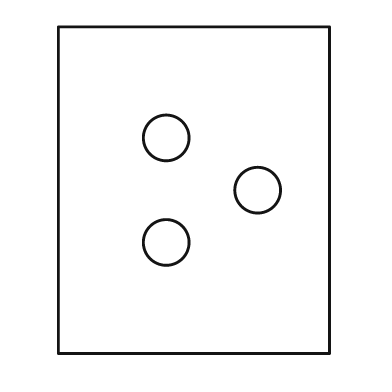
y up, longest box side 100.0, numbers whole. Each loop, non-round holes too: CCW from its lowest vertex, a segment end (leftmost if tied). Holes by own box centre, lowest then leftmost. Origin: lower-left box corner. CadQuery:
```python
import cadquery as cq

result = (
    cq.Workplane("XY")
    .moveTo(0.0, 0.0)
    .lineTo(83.0, 0.0)
    .lineTo(83.0, 100.0)
    .lineTo(0.0, 100.0)
    .close()
    .moveTo(33.0, 34.0)
    .circle(7.0)
    .moveTo(61.0, 50.0)
    .circle(7.0)
    .moveTo(33.0, 66.0)
    .circle(7.0)
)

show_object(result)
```